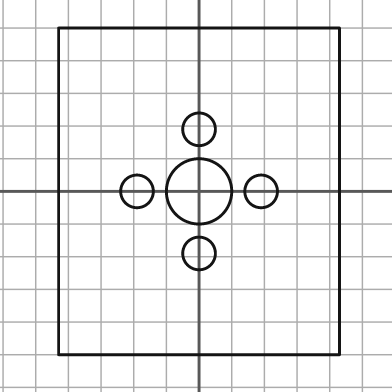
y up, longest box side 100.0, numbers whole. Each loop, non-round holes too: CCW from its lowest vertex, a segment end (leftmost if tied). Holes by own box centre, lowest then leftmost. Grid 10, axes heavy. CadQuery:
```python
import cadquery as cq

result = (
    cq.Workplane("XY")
    .moveTo(-43.0, -50.0)
    .lineTo(43.0, -50.0)
    .lineTo(43.0, 50.0)
    .lineTo(-43.0, 50.0)
    .close()
    .moveTo(0.0, -19.0)
    .circle(5.0)
    .moveTo(-19.0, 0.0)
    .circle(5.0)
    .moveTo(0.0, 0.0)
    .circle(10.0)
    .moveTo(19.0, 0.0)
    .circle(5.0)
    .moveTo(0.0, 19.0)
    .circle(5.0)
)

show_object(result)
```